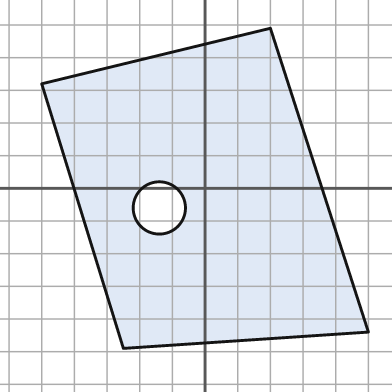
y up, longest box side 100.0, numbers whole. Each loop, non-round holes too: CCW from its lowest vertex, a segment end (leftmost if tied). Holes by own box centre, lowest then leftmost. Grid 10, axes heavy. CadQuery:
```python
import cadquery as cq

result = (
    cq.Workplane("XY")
    .moveTo(-25.0, -49.0)
    .lineTo(50.0, -44.0)
    .lineTo(20.0, 49.0)
    .lineTo(-50.0, 32.0)
    .close()
    .moveTo(-14.0, -6.0)
    .circle(8.0)
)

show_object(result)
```